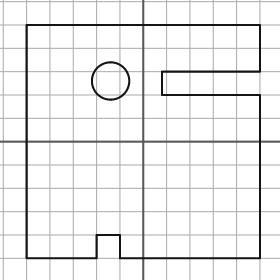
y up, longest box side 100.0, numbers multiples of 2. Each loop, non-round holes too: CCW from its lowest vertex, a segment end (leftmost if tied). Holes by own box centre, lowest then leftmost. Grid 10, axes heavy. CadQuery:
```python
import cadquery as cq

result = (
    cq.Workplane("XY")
    .moveTo(-50.0, -50.0)
    .lineTo(-20.0, -50.0)
    .lineTo(-20.0, -40.0)
    .lineTo(-10.0, -40.0)
    .lineTo(-10.0, -50.0)
    .lineTo(50.0, -50.0)
    .lineTo(50.0, 20.0)
    .lineTo(8.0, 20.0)
    .lineTo(8.0, 30.0)
    .lineTo(50.0, 30.0)
    .lineTo(50.0, 50.0)
    .lineTo(-50.0, 50.0)
    .close()
    .moveTo(-14.0, 26.0)
    .circle(8.0)
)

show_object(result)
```